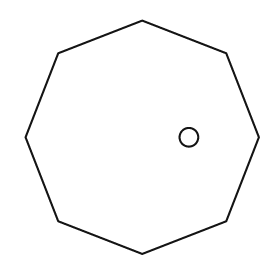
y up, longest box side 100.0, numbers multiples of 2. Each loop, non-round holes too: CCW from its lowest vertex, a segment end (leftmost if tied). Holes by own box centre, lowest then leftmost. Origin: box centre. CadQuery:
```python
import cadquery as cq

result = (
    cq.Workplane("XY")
    .moveTo(0.0, -50.0)
    .lineTo(36.0, -36.0)
    .lineTo(50.0, 0.0)
    .lineTo(36.0, 36.0)
    .lineTo(0.0, 50.0)
    .lineTo(-36.0, 36.0)
    .lineTo(-50.0, 0.0)
    .lineTo(-36.0, -36.0)
    .close()
    .moveTo(20.0, 0.0)
    .circle(4.0)
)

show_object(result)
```